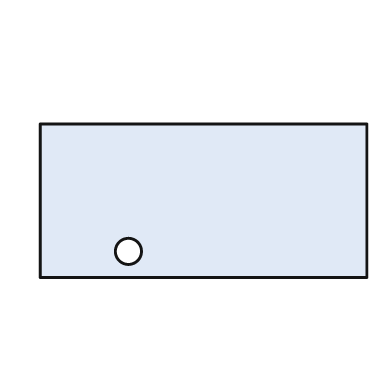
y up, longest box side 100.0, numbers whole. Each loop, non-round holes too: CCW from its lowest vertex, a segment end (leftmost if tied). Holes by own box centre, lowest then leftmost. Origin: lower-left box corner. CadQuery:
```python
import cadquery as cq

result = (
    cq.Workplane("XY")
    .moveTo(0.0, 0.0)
    .lineTo(100.0, 0.0)
    .lineTo(100.0, 47.0)
    .lineTo(0.0, 47.0)
    .close()
    .moveTo(27.0, 8.0)
    .circle(4.0)
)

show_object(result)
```